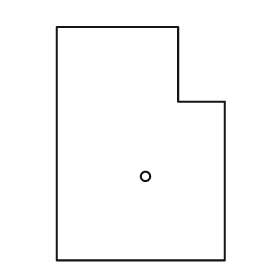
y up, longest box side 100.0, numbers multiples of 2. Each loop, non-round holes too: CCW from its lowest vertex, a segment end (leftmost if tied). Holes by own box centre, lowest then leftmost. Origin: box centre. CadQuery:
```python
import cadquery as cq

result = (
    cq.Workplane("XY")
    .moveTo(-36.0, -50.0)
    .lineTo(36.0, -50.0)
    .lineTo(36.0, 18.0)
    .lineTo(16.0, 18.0)
    .lineTo(16.0, 50.0)
    .lineTo(-36.0, 50.0)
    .close()
    .moveTo(2.0, -14.0)
    .circle(2.0)
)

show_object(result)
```